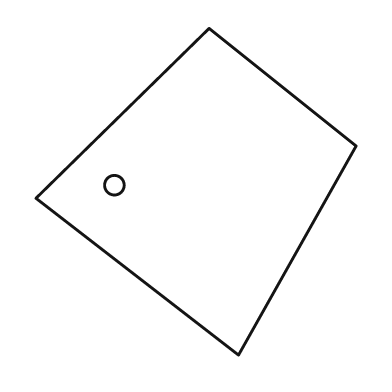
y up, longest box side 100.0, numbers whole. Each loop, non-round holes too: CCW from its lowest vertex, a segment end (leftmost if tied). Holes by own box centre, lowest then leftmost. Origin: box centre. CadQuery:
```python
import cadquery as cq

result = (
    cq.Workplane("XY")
    .moveTo(13.0, -50.0)
    .lineTo(49.0, 14.0)
    .lineTo(4.0, 50.0)
    .lineTo(-49.0, -2.0)
    .close()
    .moveTo(-25.0, 2.0)
    .circle(3.0)
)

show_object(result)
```